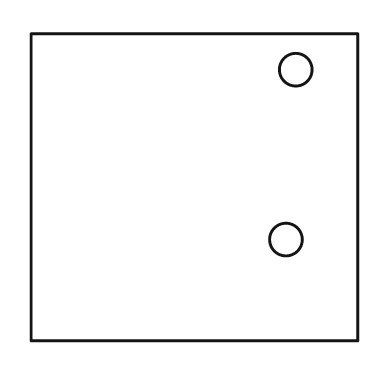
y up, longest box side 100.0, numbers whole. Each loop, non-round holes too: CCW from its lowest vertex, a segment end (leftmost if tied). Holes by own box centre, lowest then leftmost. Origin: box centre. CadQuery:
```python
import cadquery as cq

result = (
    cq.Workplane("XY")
    .moveTo(-50.0, -47.0)
    .lineTo(50.0, -47.0)
    .lineTo(50.0, 47.0)
    .lineTo(-50.0, 47.0)
    .close()
    .moveTo(28.0, -16.0)
    .circle(5.0)
    .moveTo(31.0, 36.0)
    .circle(5.0)
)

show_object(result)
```